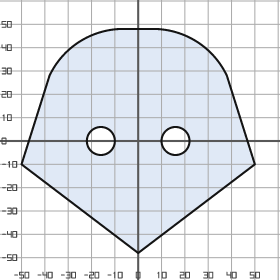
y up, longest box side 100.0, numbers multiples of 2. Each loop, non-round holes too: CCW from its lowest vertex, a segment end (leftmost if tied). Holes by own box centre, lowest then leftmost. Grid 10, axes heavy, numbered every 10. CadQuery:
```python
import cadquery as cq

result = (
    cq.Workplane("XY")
    .moveTo(0.0, -48.0)
    .lineTo(50.0, -10.0)
    .lineTo(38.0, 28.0)
    .threePointArc((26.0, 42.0), (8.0, 48.0))
    .lineTo(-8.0, 48.0)
    .threePointArc((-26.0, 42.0), (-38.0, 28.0))
    .lineTo(-50.0, -10.0)
    .close()
    .moveTo(-16.0, 0.0)
    .circle(6.0)
    .moveTo(16.0, 0.0)
    .circle(6.0)
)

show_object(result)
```